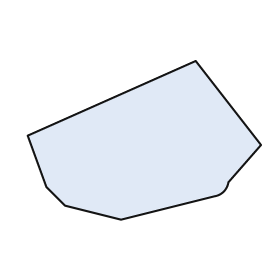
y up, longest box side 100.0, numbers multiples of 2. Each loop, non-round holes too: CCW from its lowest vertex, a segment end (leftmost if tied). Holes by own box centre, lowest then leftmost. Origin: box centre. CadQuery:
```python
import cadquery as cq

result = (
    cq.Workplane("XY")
    .moveTo(-10.0, -34.0)
    .lineTo(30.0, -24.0)
    .threePointArc((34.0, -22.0), (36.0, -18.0))
    .lineTo(50.0, -2.0)
    .lineTo(22.0, 34.0)
    .lineTo(-50.0, 2.0)
    .lineTo(-42.0, -20.0)
    .lineTo(-34.0, -28.0)
    .close()
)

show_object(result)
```